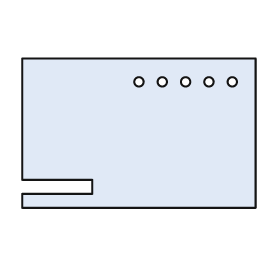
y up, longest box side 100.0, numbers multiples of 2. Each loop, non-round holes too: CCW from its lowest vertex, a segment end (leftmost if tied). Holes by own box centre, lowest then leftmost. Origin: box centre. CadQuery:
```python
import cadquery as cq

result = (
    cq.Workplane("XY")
    .moveTo(-50.0, -32.0)
    .lineTo(50.0, -32.0)
    .lineTo(50.0, 32.0)
    .lineTo(-50.0, 32.0)
    .lineTo(-50.0, -20.0)
    .lineTo(-20.0, -20.0)
    .lineTo(-20.0, -26.0)
    .lineTo(-50.0, -26.0)
    .close()
    .moveTo(0.0, 22.0)
    .circle(2.0)
    .moveTo(10.0, 22.0)
    .circle(2.0)
    .moveTo(20.0, 22.0)
    .circle(2.0)
    .moveTo(30.0, 22.0)
    .circle(2.0)
    .moveTo(40.0, 22.0)
    .circle(2.0)
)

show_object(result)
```